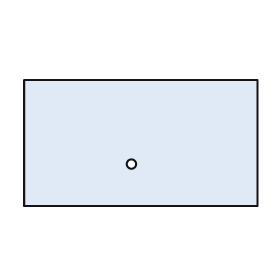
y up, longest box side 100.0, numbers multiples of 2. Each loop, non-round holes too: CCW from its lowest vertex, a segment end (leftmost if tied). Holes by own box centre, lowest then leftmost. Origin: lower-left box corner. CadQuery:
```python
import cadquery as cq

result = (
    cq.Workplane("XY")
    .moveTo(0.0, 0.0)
    .lineTo(100.0, 0.0)
    .lineTo(100.0, 54.0)
    .lineTo(0.0, 54.0)
    .close()
    .moveTo(46.0, 18.0)
    .circle(2.0)
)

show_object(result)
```